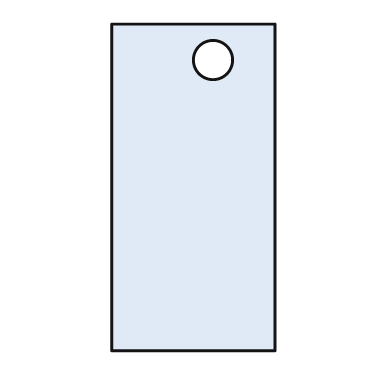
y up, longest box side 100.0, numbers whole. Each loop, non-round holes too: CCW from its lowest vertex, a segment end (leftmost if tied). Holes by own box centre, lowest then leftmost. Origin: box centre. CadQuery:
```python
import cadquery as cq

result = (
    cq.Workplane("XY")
    .moveTo(-25.0, -50.0)
    .lineTo(25.0, -50.0)
    .lineTo(25.0, 50.0)
    .lineTo(-25.0, 50.0)
    .close()
    .moveTo(6.0, 39.0)
    .circle(6.0)
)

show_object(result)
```